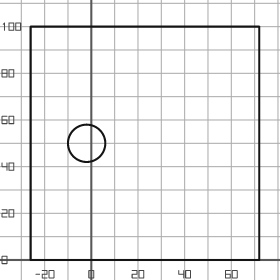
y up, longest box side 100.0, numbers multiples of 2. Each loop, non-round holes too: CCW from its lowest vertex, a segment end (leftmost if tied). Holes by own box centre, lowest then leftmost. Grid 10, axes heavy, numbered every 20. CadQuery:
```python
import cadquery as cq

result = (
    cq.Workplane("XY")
    .moveTo(-26.0, 0.0)
    .lineTo(72.0, 0.0)
    .lineTo(72.0, 100.0)
    .lineTo(-26.0, 100.0)
    .close()
    .moveTo(-2.0, 50.0)
    .circle(8.0)
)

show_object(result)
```